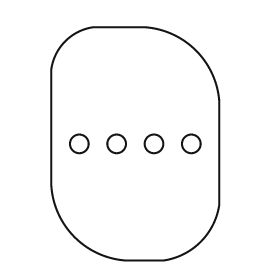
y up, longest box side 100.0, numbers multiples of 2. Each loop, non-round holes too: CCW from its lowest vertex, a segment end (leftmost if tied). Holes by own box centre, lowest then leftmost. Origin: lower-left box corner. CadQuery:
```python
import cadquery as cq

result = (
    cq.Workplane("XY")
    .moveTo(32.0, 0.0)
    .lineTo(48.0, 0.0)
    .threePointArc((64.0, 8.0), (72.0, 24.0))
    .lineTo(72.0, 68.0)
    .threePointArc((62.0, 90.0), (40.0, 100.0))
    .lineTo(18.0, 100.0)
    .threePointArc((6.0, 94.0), (0.0, 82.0))
    .lineTo(0.0, 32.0)
    .threePointArc((10.0, 10.0), (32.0, 0.0))
    .close()
    .moveTo(12.0, 50.0)
    .circle(4.0)
    .moveTo(28.0, 50.0)
    .circle(4.0)
    .moveTo(44.0, 50.0)
    .circle(4.0)
    .moveTo(60.0, 50.0)
    .circle(4.0)
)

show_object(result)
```